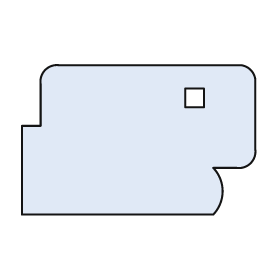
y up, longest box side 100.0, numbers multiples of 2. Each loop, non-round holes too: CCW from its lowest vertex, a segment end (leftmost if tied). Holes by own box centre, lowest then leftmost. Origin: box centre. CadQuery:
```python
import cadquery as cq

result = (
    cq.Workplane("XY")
    .moveTo(-50.0, -32.0)
    .lineTo(32.0, -32.0)
    .threePointArc((36.0, -22.0), (32.0, -12.0))
    .lineTo(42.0, -12.0)
    .threePointArc((48.0, -10.0), (50.0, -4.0))
    .lineTo(50.0, 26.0)
    .threePointArc((48.0, 30.0), (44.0, 32.0))
    .lineTo(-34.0, 32.0)
    .threePointArc((-40.0, 30.0), (-42.0, 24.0))
    .lineTo(-42.0, 6.0)
    .lineTo(-50.0, 6.0)
    .close()
    .moveTo(20.0, 14.0)
    .lineTo(28.0, 14.0)
    .lineTo(28.0, 22.0)
    .lineTo(20.0, 22.0)
    .close()
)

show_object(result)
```